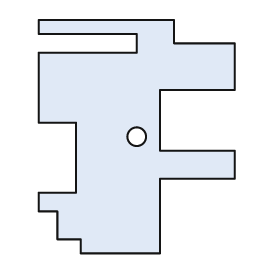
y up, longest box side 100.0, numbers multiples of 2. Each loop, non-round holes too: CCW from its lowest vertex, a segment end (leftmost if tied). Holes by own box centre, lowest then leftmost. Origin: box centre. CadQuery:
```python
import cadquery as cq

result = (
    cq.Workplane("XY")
    .moveTo(-24.0, -50.0)
    .lineTo(10.0, -50.0)
    .lineTo(10.0, -18.0)
    .lineTo(42.0, -18.0)
    .lineTo(42.0, -6.0)
    .lineTo(10.0, -6.0)
    .lineTo(10.0, 20.0)
    .lineTo(42.0, 20.0)
    .lineTo(42.0, 40.0)
    .lineTo(16.0, 40.0)
    .lineTo(16.0, 50.0)
    .lineTo(-42.0, 50.0)
    .lineTo(-42.0, 44.0)
    .lineTo(0.0, 44.0)
    .lineTo(0.0, 36.0)
    .lineTo(-42.0, 36.0)
    .lineTo(-42.0, 6.0)
    .lineTo(-26.0, 6.0)
    .lineTo(-26.0, -24.0)
    .lineTo(-42.0, -24.0)
    .lineTo(-42.0, -32.0)
    .lineTo(-34.0, -32.0)
    .lineTo(-34.0, -44.0)
    .lineTo(-24.0, -44.0)
    .close()
    .moveTo(0.0, 0.0)
    .circle(4.0)
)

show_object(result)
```